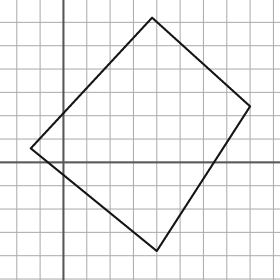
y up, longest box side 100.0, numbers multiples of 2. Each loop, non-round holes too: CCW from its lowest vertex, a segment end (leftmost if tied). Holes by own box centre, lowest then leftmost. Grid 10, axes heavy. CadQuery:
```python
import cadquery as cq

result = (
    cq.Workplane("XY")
    .moveTo(40.0, -38.0)
    .lineTo(80.0, 24.0)
    .lineTo(38.0, 62.0)
    .lineTo(-14.0, 6.0)
    .close()
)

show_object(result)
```